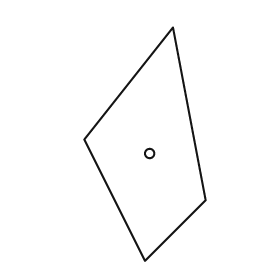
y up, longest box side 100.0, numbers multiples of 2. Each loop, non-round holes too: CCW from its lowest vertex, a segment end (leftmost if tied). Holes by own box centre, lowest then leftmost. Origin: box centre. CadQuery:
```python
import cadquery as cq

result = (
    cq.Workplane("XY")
    .moveTo(0.0, -50.0)
    .lineTo(26.0, -24.0)
    .lineTo(12.0, 50.0)
    .lineTo(-26.0, 2.0)
    .close()
    .moveTo(2.0, -4.0)
    .circle(2.0)
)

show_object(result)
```